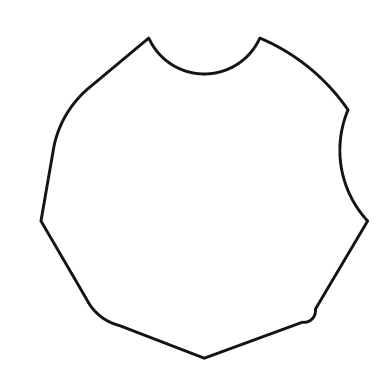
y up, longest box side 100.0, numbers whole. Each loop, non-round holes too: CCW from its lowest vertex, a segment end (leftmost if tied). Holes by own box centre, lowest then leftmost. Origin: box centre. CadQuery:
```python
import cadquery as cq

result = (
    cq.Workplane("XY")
    .moveTo(0.0, -49.0)
    .lineTo(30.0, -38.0)
    .threePointArc((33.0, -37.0), (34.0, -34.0))
    .lineTo(50.0, -7.0)
    .threePointArc((42.0, 9.0), (44.0, 27.0))
    .threePointArc((32.0, 40.0), (17.0, 49.0))
    .threePointArc((0.0, 38.0), (-17.0, 49.0))
    .lineTo(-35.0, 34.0)
    .threePointArc((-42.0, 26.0), (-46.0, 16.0))
    .lineTo(-50.0, -7.0)
    .lineTo(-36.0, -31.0)
    .threePointArc((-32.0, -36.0), (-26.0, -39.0))
    .close()
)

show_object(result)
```